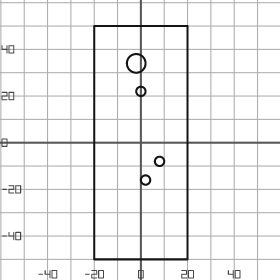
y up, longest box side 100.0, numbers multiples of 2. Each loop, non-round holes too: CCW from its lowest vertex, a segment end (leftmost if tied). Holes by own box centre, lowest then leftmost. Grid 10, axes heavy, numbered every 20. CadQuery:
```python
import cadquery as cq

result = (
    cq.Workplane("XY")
    .moveTo(-20.0, -50.0)
    .lineTo(20.0, -50.0)
    .lineTo(20.0, 50.0)
    .lineTo(-20.0, 50.0)
    .close()
    .moveTo(2.0, -16.0)
    .circle(2.0)
    .moveTo(8.0, -8.0)
    .circle(2.0)
    .moveTo(0.0, 22.0)
    .circle(2.0)
    .moveTo(-2.0, 34.0)
    .circle(4.0)
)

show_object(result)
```